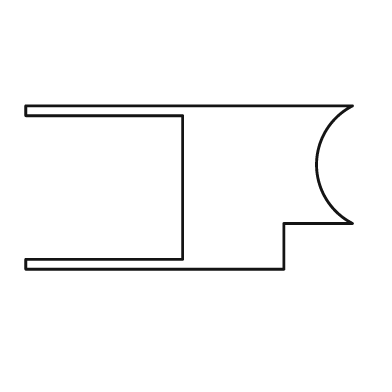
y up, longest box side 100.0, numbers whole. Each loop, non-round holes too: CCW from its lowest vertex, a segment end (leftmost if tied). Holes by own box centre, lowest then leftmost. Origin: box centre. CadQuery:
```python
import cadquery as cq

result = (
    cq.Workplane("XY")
    .moveTo(-50.0, -25.0)
    .lineTo(29.0, -25.0)
    .lineTo(29.0, -11.0)
    .lineTo(50.0, -11.0)
    .threePointArc((39.0, 7.0), (50.0, 25.0))
    .lineTo(-50.0, 25.0)
    .lineTo(-50.0, 22.0)
    .lineTo(-2.0, 22.0)
    .lineTo(-2.0, -22.0)
    .lineTo(-50.0, -22.0)
    .close()
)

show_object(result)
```